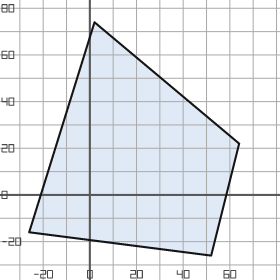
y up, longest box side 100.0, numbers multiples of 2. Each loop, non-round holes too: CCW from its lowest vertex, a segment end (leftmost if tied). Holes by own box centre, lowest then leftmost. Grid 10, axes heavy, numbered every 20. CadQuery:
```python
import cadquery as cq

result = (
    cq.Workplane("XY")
    .moveTo(52.0, -26.0)
    .lineTo(64.0, 22.0)
    .lineTo(2.0, 74.0)
    .lineTo(-26.0, -16.0)
    .close()
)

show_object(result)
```